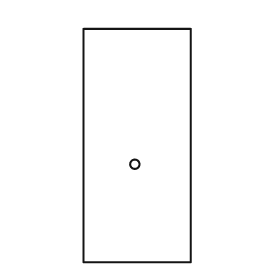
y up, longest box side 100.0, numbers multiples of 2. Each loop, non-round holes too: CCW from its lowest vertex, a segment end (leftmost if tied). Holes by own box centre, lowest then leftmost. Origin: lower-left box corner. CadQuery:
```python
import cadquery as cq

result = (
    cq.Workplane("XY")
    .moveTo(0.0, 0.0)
    .lineTo(46.0, 0.0)
    .lineTo(46.0, 100.0)
    .lineTo(0.0, 100.0)
    .close()
    .moveTo(22.0, 42.0)
    .circle(2.0)
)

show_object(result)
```